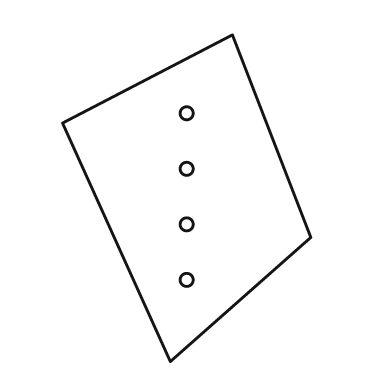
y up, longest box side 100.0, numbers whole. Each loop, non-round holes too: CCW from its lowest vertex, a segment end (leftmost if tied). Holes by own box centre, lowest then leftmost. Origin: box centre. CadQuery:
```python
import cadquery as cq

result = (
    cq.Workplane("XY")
    .moveTo(-5.0, -50.0)
    .lineTo(38.0, -12.0)
    .lineTo(14.0, 50.0)
    .lineTo(-38.0, 23.0)
    .close()
    .moveTo(0.0, -25.0)
    .circle(2.0)
    .moveTo(0.0, -8.0)
    .circle(2.0)
    .moveTo(0.0, 9.0)
    .circle(2.0)
    .moveTo(0.0, 26.0)
    .circle(2.0)
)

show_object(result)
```